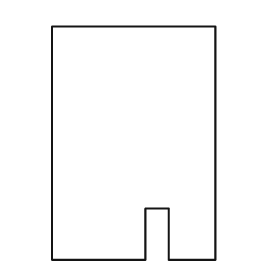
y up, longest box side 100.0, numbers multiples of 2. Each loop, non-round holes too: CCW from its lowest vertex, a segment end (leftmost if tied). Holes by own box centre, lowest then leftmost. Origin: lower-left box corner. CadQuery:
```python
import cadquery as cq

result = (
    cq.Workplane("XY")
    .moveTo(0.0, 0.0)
    .lineTo(40.0, 0.0)
    .lineTo(40.0, 22.0)
    .lineTo(50.0, 22.0)
    .lineTo(50.0, 0.0)
    .lineTo(70.0, 0.0)
    .lineTo(70.0, 100.0)
    .lineTo(0.0, 100.0)
    .close()
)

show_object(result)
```